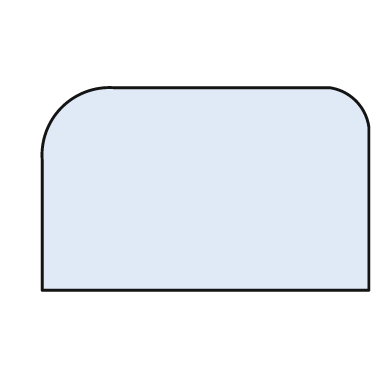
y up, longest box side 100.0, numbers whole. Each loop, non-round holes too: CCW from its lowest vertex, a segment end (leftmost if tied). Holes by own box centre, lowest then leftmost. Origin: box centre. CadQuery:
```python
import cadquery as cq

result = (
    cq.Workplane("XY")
    .moveTo(-50.0, -31.0)
    .lineTo(50.0, -31.0)
    .lineTo(50.0, 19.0)
    .threePointArc((46.0, 27.0), (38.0, 31.0))
    .lineTo(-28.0, 31.0)
    .threePointArc((-44.0, 25.0), (-50.0, 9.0))
    .close()
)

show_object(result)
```